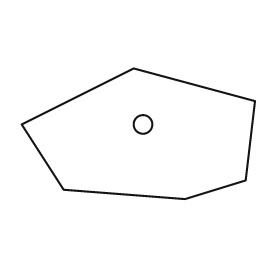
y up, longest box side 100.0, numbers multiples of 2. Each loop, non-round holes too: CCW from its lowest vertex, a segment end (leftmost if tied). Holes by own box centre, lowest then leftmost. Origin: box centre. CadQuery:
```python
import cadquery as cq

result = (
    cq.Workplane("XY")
    .moveTo(20.0, -28.0)
    .lineTo(46.0, -20.0)
    .lineTo(50.0, 14.0)
    .lineTo(-2.0, 28.0)
    .lineTo(-50.0, 4.0)
    .lineTo(-32.0, -24.0)
    .close()
    .moveTo(2.0, 4.0)
    .circle(4.0)
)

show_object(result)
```